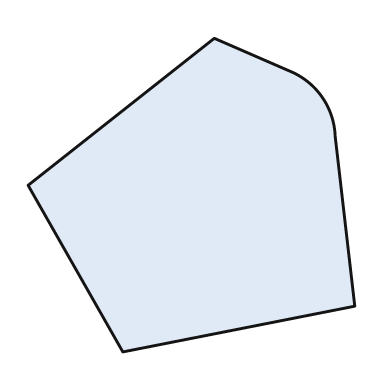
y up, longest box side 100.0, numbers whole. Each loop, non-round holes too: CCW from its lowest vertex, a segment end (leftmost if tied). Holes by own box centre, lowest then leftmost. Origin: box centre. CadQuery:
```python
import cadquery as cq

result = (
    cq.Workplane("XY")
    .moveTo(-21.0, -48.0)
    .lineTo(50.0, -34.0)
    .lineTo(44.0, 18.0)
    .threePointArc((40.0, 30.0), (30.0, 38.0))
    .lineTo(7.0, 48.0)
    .lineTo(-50.0, 3.0)
    .close()
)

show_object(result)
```